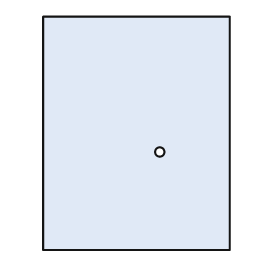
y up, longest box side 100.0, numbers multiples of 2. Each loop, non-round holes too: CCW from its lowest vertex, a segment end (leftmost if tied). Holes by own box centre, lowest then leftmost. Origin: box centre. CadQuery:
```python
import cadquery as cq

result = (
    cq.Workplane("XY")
    .moveTo(-40.0, -50.0)
    .lineTo(40.0, -50.0)
    .lineTo(40.0, 50.0)
    .lineTo(-40.0, 50.0)
    .close()
    .moveTo(10.0, -8.0)
    .circle(2.0)
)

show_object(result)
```